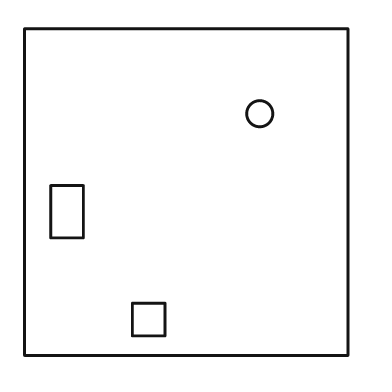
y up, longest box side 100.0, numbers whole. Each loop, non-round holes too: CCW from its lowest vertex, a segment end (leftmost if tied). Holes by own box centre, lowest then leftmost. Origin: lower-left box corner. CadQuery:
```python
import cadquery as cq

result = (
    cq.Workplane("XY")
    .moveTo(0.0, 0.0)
    .lineTo(99.0, 0.0)
    .lineTo(99.0, 100.0)
    .lineTo(0.0, 100.0)
    .close()
    .moveTo(33.0, 6.0)
    .lineTo(43.0, 6.0)
    .lineTo(43.0, 16.0)
    .lineTo(33.0, 16.0)
    .close()
    .moveTo(8.0, 36.0)
    .lineTo(18.0, 36.0)
    .lineTo(18.0, 52.0)
    .lineTo(8.0, 52.0)
    .close()
    .moveTo(72.0, 74.0)
    .circle(4.0)
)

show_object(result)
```